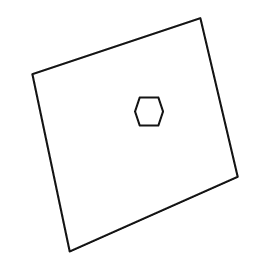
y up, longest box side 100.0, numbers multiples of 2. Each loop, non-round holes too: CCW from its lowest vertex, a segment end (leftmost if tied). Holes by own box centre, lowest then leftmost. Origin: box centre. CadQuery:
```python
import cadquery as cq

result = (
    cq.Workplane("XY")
    .moveTo(-28.0, -50.0)
    .lineTo(44.0, -18.0)
    .lineTo(28.0, 50.0)
    .lineTo(-44.0, 26.0)
    .close()
    .moveTo(2.0, 4.0)
    .lineTo(10.0, 4.0)
    .lineTo(12.0, 10.0)
    .lineTo(10.0, 16.0)
    .lineTo(2.0, 16.0)
    .lineTo(0.0, 10.0)
    .close()
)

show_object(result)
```